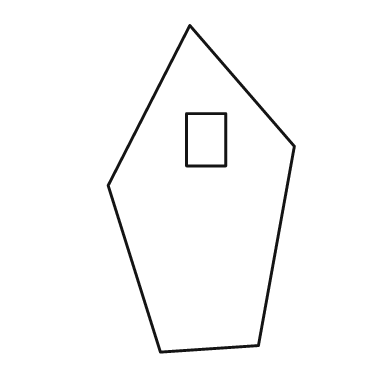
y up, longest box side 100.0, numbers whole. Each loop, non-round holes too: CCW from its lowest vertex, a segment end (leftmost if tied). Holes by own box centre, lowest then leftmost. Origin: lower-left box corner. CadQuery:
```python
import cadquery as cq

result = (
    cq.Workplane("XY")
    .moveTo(16.0, 0.0)
    .lineTo(46.0, 2.0)
    .lineTo(57.0, 63.0)
    .lineTo(25.0, 100.0)
    .lineTo(0.0, 51.0)
    .close()
    .moveTo(24.0, 57.0)
    .lineTo(36.0, 57.0)
    .lineTo(36.0, 73.0)
    .lineTo(24.0, 73.0)
    .close()
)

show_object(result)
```